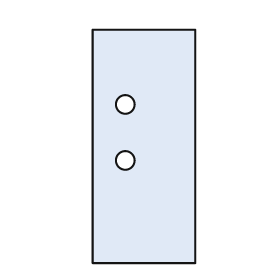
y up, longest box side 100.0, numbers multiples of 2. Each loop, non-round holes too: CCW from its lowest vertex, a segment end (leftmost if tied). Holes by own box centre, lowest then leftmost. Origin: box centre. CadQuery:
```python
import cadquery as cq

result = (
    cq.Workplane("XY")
    .moveTo(-22.0, -50.0)
    .lineTo(22.0, -50.0)
    .lineTo(22.0, 50.0)
    .lineTo(-22.0, 50.0)
    .close()
    .moveTo(-8.0, -6.0)
    .circle(4.0)
    .moveTo(-8.0, 18.0)
    .circle(4.0)
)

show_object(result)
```